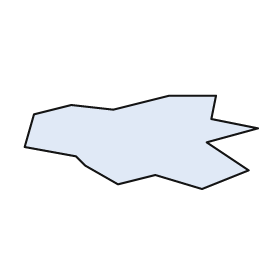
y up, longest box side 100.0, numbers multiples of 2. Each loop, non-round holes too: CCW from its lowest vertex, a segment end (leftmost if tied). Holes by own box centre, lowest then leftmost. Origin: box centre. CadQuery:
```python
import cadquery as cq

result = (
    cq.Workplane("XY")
    .moveTo(26.0, -20.0)
    .lineTo(46.0, -12.0)
    .lineTo(28.0, 0.0)
    .lineTo(50.0, 6.0)
    .lineTo(30.0, 10.0)
    .lineTo(32.0, 20.0)
    .lineTo(12.0, 20.0)
    .lineTo(-12.0, 14.0)
    .lineTo(-30.0, 16.0)
    .lineTo(-46.0, 12.0)
    .lineTo(-50.0, -2.0)
    .lineTo(-28.0, -6.0)
    .lineTo(-24.0, -10.0)
    .lineTo(-10.0, -18.0)
    .lineTo(6.0, -14.0)
    .close()
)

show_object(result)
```